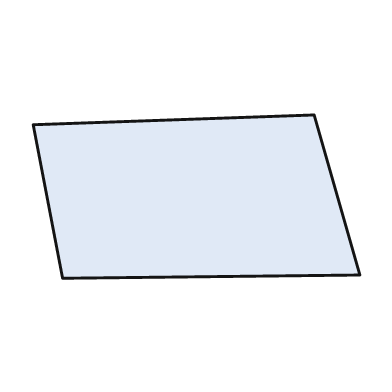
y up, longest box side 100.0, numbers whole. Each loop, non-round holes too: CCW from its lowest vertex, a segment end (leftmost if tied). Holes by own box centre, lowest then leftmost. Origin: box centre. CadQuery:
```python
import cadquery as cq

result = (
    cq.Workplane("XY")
    .moveTo(-41.0, -25.0)
    .lineTo(50.0, -24.0)
    .lineTo(36.0, 25.0)
    .lineTo(-50.0, 22.0)
    .close()
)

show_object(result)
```